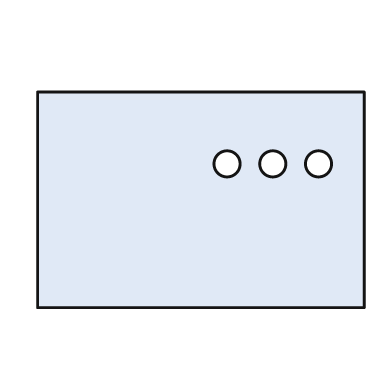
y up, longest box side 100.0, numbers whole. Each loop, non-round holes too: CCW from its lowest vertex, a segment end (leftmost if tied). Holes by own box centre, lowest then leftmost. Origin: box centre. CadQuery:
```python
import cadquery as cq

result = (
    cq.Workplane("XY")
    .moveTo(-50.0, -33.0)
    .lineTo(50.0, -33.0)
    .lineTo(50.0, 33.0)
    .lineTo(-50.0, 33.0)
    .close()
    .moveTo(8.0, 11.0)
    .circle(4.0)
    .moveTo(22.0, 11.0)
    .circle(4.0)
    .moveTo(36.0, 11.0)
    .circle(4.0)
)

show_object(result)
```